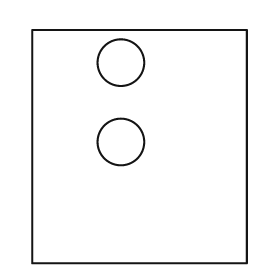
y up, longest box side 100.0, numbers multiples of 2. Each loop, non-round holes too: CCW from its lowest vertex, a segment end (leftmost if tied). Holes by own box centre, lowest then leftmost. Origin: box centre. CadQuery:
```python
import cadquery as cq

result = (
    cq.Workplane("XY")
    .moveTo(-46.0, -50.0)
    .lineTo(46.0, -50.0)
    .lineTo(46.0, 50.0)
    .lineTo(-46.0, 50.0)
    .close()
    .moveTo(-8.0, 2.0)
    .circle(10.0)
    .moveTo(-8.0, 36.0)
    .circle(10.0)
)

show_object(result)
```